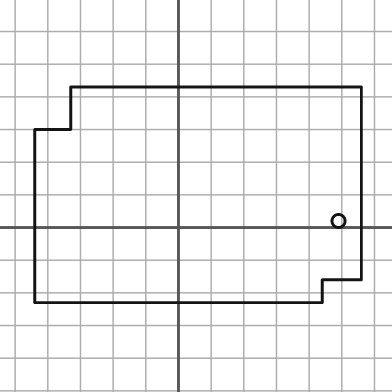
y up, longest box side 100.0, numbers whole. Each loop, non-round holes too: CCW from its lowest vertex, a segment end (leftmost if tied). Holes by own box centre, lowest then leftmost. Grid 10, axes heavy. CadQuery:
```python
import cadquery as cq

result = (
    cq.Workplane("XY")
    .moveTo(-44.0, -23.0)
    .lineTo(44.0, -23.0)
    .lineTo(44.0, -16.0)
    .lineTo(56.0, -16.0)
    .lineTo(56.0, 43.0)
    .lineTo(-33.0, 43.0)
    .lineTo(-33.0, 30.0)
    .lineTo(-44.0, 30.0)
    .close()
    .moveTo(49.0, 2.0)
    .circle(2.0)
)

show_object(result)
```